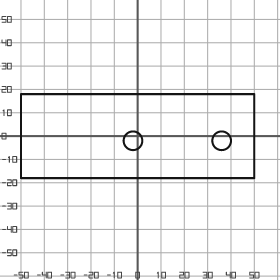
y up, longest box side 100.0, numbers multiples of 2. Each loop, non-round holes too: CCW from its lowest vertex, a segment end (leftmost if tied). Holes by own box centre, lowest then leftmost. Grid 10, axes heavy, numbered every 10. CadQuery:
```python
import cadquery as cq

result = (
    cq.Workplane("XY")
    .moveTo(-50.0, -18.0)
    .lineTo(50.0, -18.0)
    .lineTo(50.0, 18.0)
    .lineTo(-50.0, 18.0)
    .close()
    .moveTo(-2.0, -2.0)
    .circle(4.0)
    .moveTo(36.0, -2.0)
    .circle(4.0)
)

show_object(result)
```